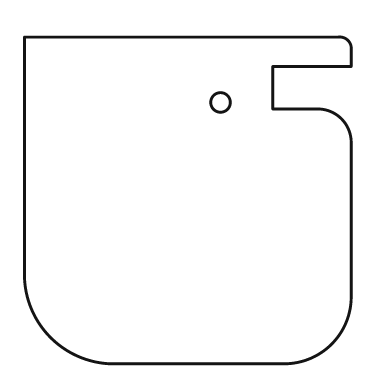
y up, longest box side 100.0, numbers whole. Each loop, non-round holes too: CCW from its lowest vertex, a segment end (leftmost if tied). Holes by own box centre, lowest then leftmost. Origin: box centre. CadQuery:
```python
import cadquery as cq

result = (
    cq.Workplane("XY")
    .moveTo(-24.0, -50.0)
    .lineTo(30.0, -50.0)
    .threePointArc((44.0, -44.0), (50.0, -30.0))
    .lineTo(50.0, 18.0)
    .threePointArc((47.0, 25.0), (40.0, 28.0))
    .lineTo(26.0, 28.0)
    .lineTo(26.0, 41.0)
    .lineTo(50.0, 41.0)
    .lineTo(50.0, 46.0)
    .threePointArc((49.0, 49.0), (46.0, 50.0))
    .lineTo(-50.0, 50.0)
    .lineTo(-50.0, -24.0)
    .threePointArc((-42.0, -42.0), (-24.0, -50.0))
    .close()
    .moveTo(10.0, 30.0)
    .circle(3.0)
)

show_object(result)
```